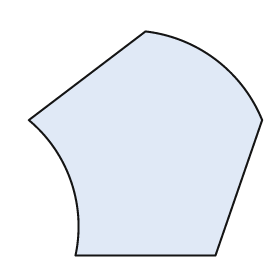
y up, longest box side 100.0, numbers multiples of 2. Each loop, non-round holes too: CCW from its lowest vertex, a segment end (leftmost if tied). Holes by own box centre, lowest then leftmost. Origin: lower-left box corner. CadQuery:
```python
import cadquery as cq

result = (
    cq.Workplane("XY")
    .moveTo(20.0, 0.0)
    .lineTo(80.0, 0.0)
    .lineTo(100.0, 58.0)
    .threePointArc((80.0, 84.0), (50.0, 96.0))
    .lineTo(0.0, 58.0)
    .threePointArc((18.0, 32.0), (20.0, 0.0))
    .close()
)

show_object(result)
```